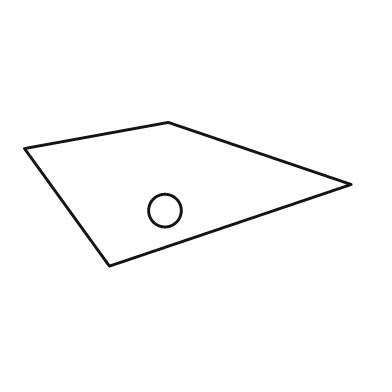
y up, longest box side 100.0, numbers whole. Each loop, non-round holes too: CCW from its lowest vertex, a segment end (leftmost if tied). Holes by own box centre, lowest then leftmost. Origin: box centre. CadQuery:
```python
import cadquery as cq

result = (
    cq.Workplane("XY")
    .moveTo(-24.0, -22.0)
    .lineTo(50.0, 3.0)
    .lineTo(-6.0, 22.0)
    .lineTo(-50.0, 14.0)
    .close()
    .moveTo(-7.0, -5.0)
    .circle(5.0)
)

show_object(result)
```